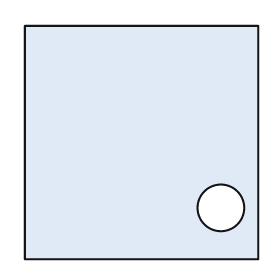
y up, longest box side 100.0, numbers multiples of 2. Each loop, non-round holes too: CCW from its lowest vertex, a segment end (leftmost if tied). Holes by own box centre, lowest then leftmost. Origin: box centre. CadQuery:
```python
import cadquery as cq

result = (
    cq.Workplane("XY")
    .moveTo(-50.0, -50.0)
    .lineTo(50.0, -50.0)
    .lineTo(50.0, 50.0)
    .lineTo(-50.0, 50.0)
    .close()
    .moveTo(34.0, -28.0)
    .circle(10.0)
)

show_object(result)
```